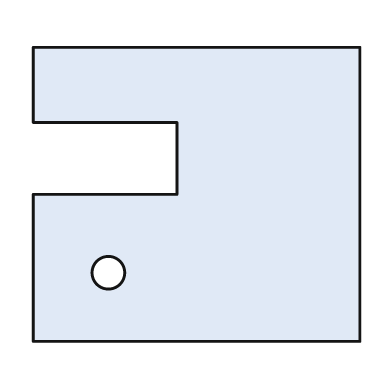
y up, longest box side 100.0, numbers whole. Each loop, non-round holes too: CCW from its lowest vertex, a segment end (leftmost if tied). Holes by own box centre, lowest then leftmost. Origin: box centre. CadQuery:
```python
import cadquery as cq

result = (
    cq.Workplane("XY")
    .moveTo(-50.0, -45.0)
    .lineTo(50.0, -45.0)
    .lineTo(50.0, 45.0)
    .lineTo(-50.0, 45.0)
    .lineTo(-50.0, 22.0)
    .lineTo(-6.0, 22.0)
    .lineTo(-6.0, 0.0)
    .lineTo(-50.0, 0.0)
    .close()
    .moveTo(-27.0, -24.0)
    .circle(5.0)
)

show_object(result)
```